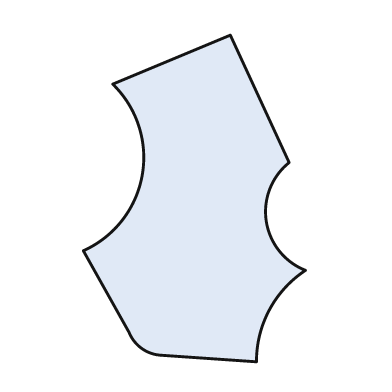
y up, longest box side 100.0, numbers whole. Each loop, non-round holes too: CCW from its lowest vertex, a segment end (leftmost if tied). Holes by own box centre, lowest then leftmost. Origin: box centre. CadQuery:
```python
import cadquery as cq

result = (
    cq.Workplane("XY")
    .moveTo(19.0, -50.0)
    .threePointArc((23.0, -34.0), (34.0, -22.0))
    .threePointArc((22.0, -7.0), (29.0, 11.0))
    .lineTo(11.0, 50.0)
    .lineTo(-25.0, 35.0)
    .threePointArc((-16.0, 7.0), (-34.0, -16.0))
    .lineTo(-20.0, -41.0)
    .threePointArc((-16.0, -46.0), (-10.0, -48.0))
    .close()
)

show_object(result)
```